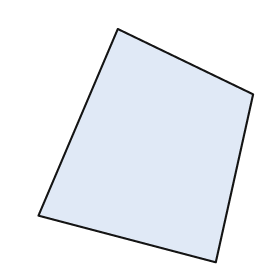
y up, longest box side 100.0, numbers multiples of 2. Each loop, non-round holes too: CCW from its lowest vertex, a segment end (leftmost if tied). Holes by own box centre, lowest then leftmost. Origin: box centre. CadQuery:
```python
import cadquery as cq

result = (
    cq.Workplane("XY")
    .moveTo(30.0, -50.0)
    .lineTo(46.0, 22.0)
    .lineTo(-12.0, 50.0)
    .lineTo(-46.0, -30.0)
    .close()
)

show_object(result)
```